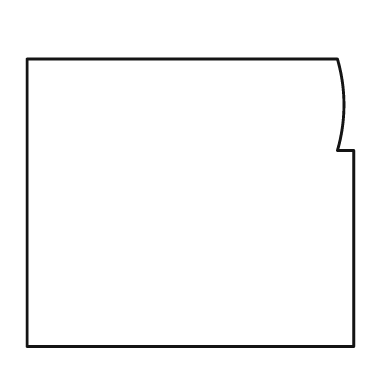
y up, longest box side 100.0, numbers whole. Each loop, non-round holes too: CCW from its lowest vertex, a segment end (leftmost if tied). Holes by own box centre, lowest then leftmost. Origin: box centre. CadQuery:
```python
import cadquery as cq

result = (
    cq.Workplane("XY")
    .moveTo(-50.0, -44.0)
    .lineTo(50.0, -44.0)
    .lineTo(50.0, 16.0)
    .lineTo(45.0, 16.0)
    .threePointArc((47.0, 30.0), (45.0, 44.0))
    .lineTo(-50.0, 44.0)
    .close()
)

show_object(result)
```